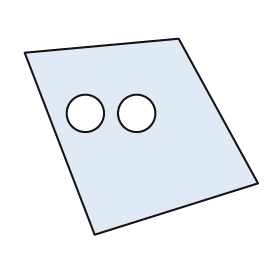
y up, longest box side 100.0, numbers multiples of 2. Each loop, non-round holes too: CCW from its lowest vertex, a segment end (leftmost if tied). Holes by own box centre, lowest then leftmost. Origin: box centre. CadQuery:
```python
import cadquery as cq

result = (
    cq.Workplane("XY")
    .moveTo(-20.0, -42.0)
    .lineTo(50.0, -20.0)
    .lineTo(16.0, 42.0)
    .lineTo(-50.0, 36.0)
    .close()
    .moveTo(-24.0, 10.0)
    .circle(8.0)
    .moveTo(-2.0, 10.0)
    .circle(8.0)
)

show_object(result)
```